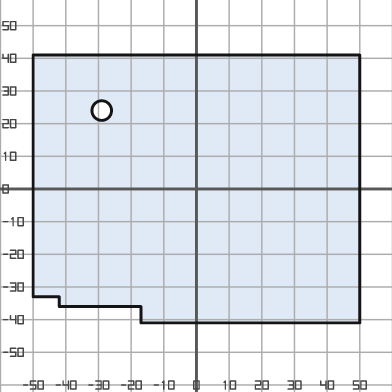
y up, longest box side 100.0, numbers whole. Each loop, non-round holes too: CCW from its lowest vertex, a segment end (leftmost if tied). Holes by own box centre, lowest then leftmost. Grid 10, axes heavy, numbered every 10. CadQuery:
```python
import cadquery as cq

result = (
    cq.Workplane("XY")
    .moveTo(-17.0, -41.0)
    .lineTo(50.0, -41.0)
    .lineTo(50.0, 41.0)
    .lineTo(-50.0, 41.0)
    .lineTo(-50.0, -33.0)
    .lineTo(-42.0, -33.0)
    .lineTo(-42.0, -36.0)
    .lineTo(-17.0, -36.0)
    .close()
    .moveTo(-29.0, 24.0)
    .circle(3.0)
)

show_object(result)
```